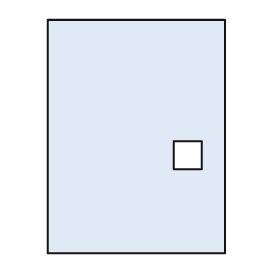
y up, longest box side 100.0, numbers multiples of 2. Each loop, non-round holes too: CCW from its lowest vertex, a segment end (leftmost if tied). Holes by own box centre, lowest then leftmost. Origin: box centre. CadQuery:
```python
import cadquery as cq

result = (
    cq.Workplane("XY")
    .moveTo(-38.0, -50.0)
    .lineTo(38.0, -50.0)
    .lineTo(38.0, 50.0)
    .lineTo(-38.0, 50.0)
    .close()
    .moveTo(16.0, -14.0)
    .lineTo(28.0, -14.0)
    .lineTo(28.0, -2.0)
    .lineTo(16.0, -2.0)
    .close()
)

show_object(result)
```